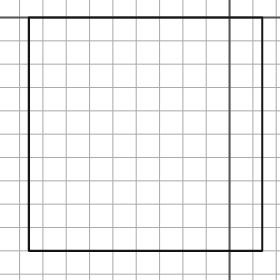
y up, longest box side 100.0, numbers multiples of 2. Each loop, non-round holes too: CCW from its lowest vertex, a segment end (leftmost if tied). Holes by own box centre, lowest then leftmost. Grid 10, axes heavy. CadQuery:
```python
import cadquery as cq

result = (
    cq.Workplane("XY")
    .moveTo(-86.0, -100.0)
    .lineTo(14.0, -100.0)
    .lineTo(14.0, 0.0)
    .lineTo(-86.0, 0.0)
    .close()
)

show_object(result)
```